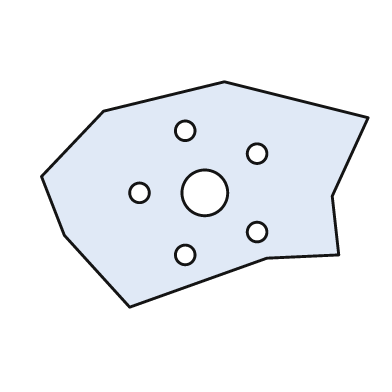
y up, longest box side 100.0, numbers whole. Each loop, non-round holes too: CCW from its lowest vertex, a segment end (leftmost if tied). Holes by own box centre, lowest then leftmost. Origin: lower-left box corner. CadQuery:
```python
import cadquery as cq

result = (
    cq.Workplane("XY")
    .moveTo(27.0, 0.0)
    .lineTo(69.0, 15.0)
    .lineTo(91.0, 16.0)
    .lineTo(89.0, 34.0)
    .lineTo(100.0, 58.0)
    .lineTo(56.0, 69.0)
    .lineTo(19.0, 60.0)
    .lineTo(0.0, 40.0)
    .lineTo(7.0, 22.0)
    .close()
    .moveTo(44.0, 16.0)
    .circle(3.0)
    .moveTo(66.0, 23.0)
    .circle(3.0)
    .moveTo(30.0, 35.0)
    .circle(3.0)
    .moveTo(50.0, 35.0)
    .circle(7.0)
    .moveTo(66.0, 47.0)
    .circle(3.0)
    .moveTo(44.0, 54.0)
    .circle(3.0)
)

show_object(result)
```